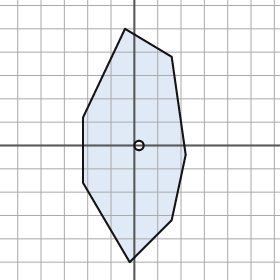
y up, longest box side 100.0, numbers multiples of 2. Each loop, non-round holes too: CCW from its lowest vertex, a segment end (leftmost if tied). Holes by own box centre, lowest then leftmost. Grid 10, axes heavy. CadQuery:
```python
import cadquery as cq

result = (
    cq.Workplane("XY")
    .moveTo(-2.0, -50.0)
    .lineTo(16.0, -32.0)
    .lineTo(22.0, -4.0)
    .lineTo(16.0, 38.0)
    .lineTo(-4.0, 50.0)
    .lineTo(-22.0, 12.0)
    .lineTo(-22.0, -16.0)
    .close()
    .moveTo(2.0, 0.0)
    .circle(2.0)
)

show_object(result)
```